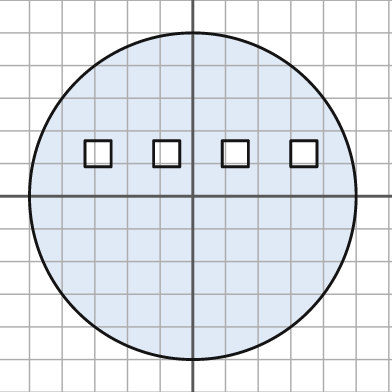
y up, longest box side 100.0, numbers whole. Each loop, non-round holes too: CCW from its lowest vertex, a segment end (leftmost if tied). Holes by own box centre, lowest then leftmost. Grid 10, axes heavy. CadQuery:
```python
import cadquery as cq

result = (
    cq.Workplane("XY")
    .moveTo(0.0, 0.0)
    .circle(50.0)
    .moveTo(-33.0, 9.0)
    .lineTo(-25.0, 9.0)
    .lineTo(-25.0, 17.0)
    .lineTo(-33.0, 17.0)
    .close()
    .moveTo(-12.0, 9.0)
    .lineTo(-4.0, 9.0)
    .lineTo(-4.0, 17.0)
    .lineTo(-12.0, 17.0)
    .close()
    .moveTo(9.0, 9.0)
    .lineTo(17.0, 9.0)
    .lineTo(17.0, 17.0)
    .lineTo(9.0, 17.0)
    .close()
    .moveTo(30.0, 9.0)
    .lineTo(38.0, 9.0)
    .lineTo(38.0, 17.0)
    .lineTo(30.0, 17.0)
    .close()
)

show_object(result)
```